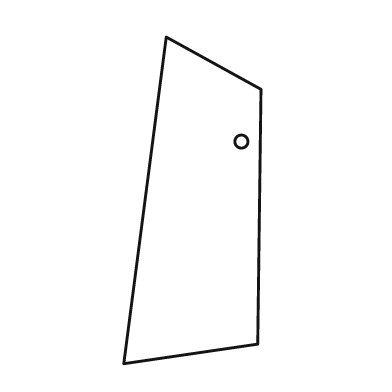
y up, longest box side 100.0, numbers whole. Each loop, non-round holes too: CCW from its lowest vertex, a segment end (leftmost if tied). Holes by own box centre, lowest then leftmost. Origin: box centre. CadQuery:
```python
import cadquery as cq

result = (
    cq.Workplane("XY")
    .moveTo(-21.0, -50.0)
    .lineTo(20.0, -44.0)
    .lineTo(21.0, 34.0)
    .lineTo(-8.0, 50.0)
    .close()
    .moveTo(15.0, 18.0)
    .circle(2.0)
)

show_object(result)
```